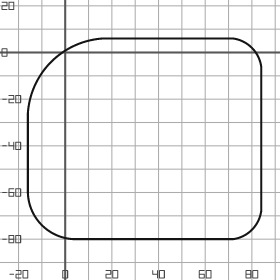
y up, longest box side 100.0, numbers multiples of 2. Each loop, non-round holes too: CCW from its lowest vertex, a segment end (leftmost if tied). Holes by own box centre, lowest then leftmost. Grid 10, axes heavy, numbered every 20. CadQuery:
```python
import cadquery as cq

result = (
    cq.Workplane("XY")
    .moveTo(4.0, -80.0)
    .lineTo(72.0, -80.0)
    .threePointArc((80.0, -76.0), (84.0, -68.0))
    .lineTo(84.0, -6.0)
    .threePointArc((80.0, 2.0), (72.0, 6.0))
    .lineTo(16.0, 6.0)
    .threePointArc((-6.0, -4.0), (-16.0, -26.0))
    .lineTo(-16.0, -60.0)
    .threePointArc((-10.0, -74.0), (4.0, -80.0))
    .close()
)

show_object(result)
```